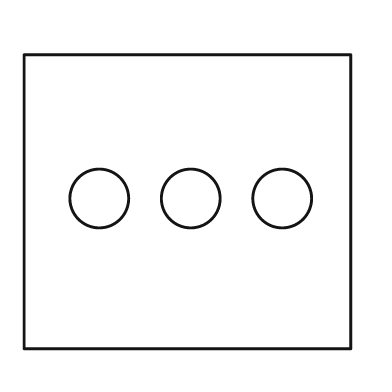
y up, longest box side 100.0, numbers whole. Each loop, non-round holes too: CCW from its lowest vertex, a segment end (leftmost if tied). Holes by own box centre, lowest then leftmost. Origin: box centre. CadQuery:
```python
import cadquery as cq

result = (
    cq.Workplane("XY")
    .moveTo(-50.0, -45.0)
    .lineTo(50.0, -45.0)
    .lineTo(50.0, 45.0)
    .lineTo(-50.0, 45.0)
    .close()
    .moveTo(-27.0, 1.0)
    .circle(9.0)
    .moveTo(1.0, 1.0)
    .circle(9.0)
    .moveTo(29.0, 1.0)
    .circle(9.0)
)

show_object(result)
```